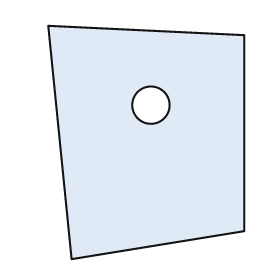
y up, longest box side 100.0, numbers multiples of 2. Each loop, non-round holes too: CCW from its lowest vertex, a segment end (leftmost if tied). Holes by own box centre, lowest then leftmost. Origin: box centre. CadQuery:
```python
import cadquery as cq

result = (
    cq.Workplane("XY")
    .moveTo(-32.0, -50.0)
    .lineTo(42.0, -38.0)
    .lineTo(42.0, 46.0)
    .lineTo(-42.0, 50.0)
    .close()
    .moveTo(2.0, 16.0)
    .circle(8.0)
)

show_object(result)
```